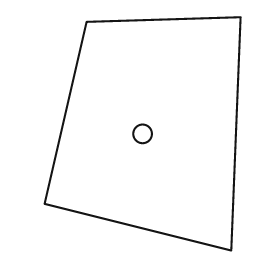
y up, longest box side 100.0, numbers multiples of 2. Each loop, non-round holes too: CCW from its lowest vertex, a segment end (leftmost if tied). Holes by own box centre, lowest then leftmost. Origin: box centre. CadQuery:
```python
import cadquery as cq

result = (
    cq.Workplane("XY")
    .moveTo(38.0, -50.0)
    .lineTo(42.0, 50.0)
    .lineTo(-24.0, 48.0)
    .lineTo(-42.0, -30.0)
    .close()
    .moveTo(0.0, 0.0)
    .circle(4.0)
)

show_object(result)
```